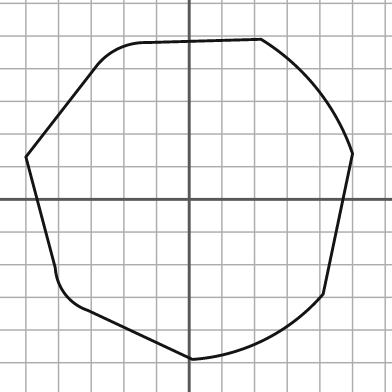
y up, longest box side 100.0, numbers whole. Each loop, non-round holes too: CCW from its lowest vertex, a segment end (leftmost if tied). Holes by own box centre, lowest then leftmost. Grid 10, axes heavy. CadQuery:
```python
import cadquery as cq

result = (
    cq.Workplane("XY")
    .moveTo(1.0, -49.0)
    .threePointArc((23.0, -43.0), (41.0, -29.0))
    .lineTo(50.0, 14.0)
    .threePointArc((39.0, 34.0), (22.0, 49.0))
    .lineTo(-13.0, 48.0)
    .threePointArc((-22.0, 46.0), (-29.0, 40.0))
    .lineTo(-50.0, 13.0)
    .lineTo(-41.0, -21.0)
    .threePointArc((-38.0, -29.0), (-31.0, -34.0))
    .close()
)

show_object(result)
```